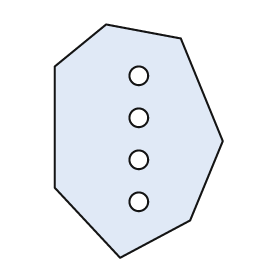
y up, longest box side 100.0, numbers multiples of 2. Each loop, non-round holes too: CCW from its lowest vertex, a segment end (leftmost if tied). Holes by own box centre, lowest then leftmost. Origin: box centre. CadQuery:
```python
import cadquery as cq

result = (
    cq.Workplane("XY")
    .moveTo(-8.0, -50.0)
    .lineTo(22.0, -34.0)
    .lineTo(36.0, 0.0)
    .lineTo(18.0, 44.0)
    .lineTo(-14.0, 50.0)
    .lineTo(-36.0, 32.0)
    .lineTo(-36.0, -20.0)
    .close()
    .moveTo(0.0, -26.0)
    .circle(4.0)
    .moveTo(0.0, -8.0)
    .circle(4.0)
    .moveTo(0.0, 10.0)
    .circle(4.0)
    .moveTo(0.0, 28.0)
    .circle(4.0)
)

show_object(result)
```